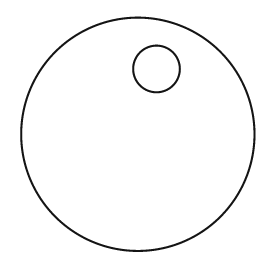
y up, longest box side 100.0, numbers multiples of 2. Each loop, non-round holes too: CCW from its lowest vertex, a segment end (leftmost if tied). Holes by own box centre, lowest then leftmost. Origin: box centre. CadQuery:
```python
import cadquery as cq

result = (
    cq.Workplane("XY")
    .moveTo(0.0, 0.0)
    .circle(50.0)
    .moveTo(8.0, 28.0)
    .circle(10.0)
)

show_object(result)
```